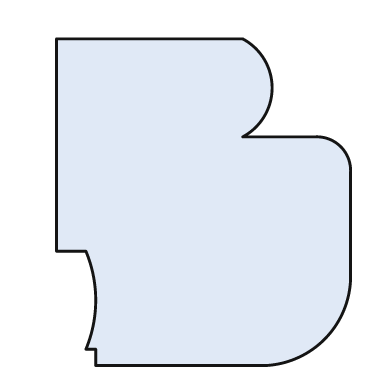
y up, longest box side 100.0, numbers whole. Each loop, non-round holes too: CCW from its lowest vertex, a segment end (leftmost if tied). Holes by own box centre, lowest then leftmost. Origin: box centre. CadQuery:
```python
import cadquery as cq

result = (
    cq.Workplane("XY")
    .moveTo(-33.0, -50.0)
    .lineTo(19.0, -50.0)
    .threePointArc((37.0, -42.0), (45.0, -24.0))
    .lineTo(45.0, 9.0)
    .threePointArc((42.0, 17.0), (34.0, 20.0))
    .lineTo(12.0, 20.0)
    .threePointArc((21.0, 35.0), (12.0, 50.0))
    .lineTo(-45.0, 50.0)
    .lineTo(-45.0, -15.0)
    .lineTo(-36.0, -15.0)
    .threePointArc((-33.0, -30.0), (-36.0, -45.0))
    .lineTo(-33.0, -45.0)
    .close()
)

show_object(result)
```